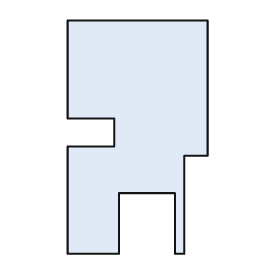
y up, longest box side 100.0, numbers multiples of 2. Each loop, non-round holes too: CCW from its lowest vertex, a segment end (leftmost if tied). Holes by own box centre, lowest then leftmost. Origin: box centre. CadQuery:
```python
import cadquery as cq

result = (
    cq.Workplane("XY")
    .moveTo(-30.0, -50.0)
    .lineTo(-8.0, -50.0)
    .lineTo(-8.0, -24.0)
    .lineTo(16.0, -24.0)
    .lineTo(16.0, -50.0)
    .lineTo(20.0, -50.0)
    .lineTo(20.0, -8.0)
    .lineTo(30.0, -8.0)
    .lineTo(30.0, 50.0)
    .lineTo(-30.0, 50.0)
    .lineTo(-30.0, 8.0)
    .lineTo(-10.0, 8.0)
    .lineTo(-10.0, -4.0)
    .lineTo(-30.0, -4.0)
    .close()
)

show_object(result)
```